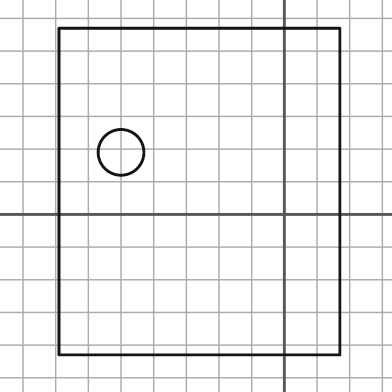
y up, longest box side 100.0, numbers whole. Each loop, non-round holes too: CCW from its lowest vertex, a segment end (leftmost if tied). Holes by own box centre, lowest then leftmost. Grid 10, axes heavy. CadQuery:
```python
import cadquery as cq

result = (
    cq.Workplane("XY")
    .moveTo(-69.0, -43.0)
    .lineTo(17.0, -43.0)
    .lineTo(17.0, 57.0)
    .lineTo(-69.0, 57.0)
    .close()
    .moveTo(-50.0, 19.0)
    .circle(7.0)
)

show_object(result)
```